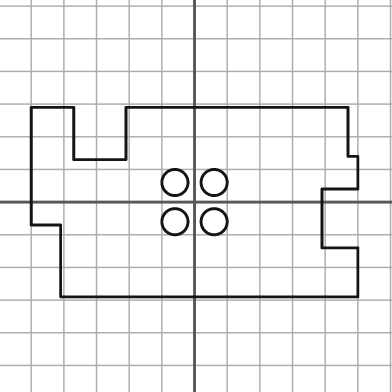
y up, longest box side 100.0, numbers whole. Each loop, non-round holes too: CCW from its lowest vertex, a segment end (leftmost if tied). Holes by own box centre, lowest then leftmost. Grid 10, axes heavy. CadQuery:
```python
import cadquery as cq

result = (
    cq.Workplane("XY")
    .moveTo(-41.0, -29.0)
    .lineTo(50.0, -29.0)
    .lineTo(50.0, -14.0)
    .lineTo(39.0, -14.0)
    .lineTo(39.0, 4.0)
    .lineTo(50.0, 4.0)
    .lineTo(50.0, 14.0)
    .lineTo(47.0, 14.0)
    .lineTo(47.0, 29.0)
    .lineTo(-21.0, 29.0)
    .lineTo(-21.0, 13.0)
    .lineTo(-37.0, 13.0)
    .lineTo(-37.0, 29.0)
    .lineTo(-50.0, 29.0)
    .lineTo(-50.0, -7.0)
    .lineTo(-41.0, -7.0)
    .close()
    .moveTo(-6.0, -6.0)
    .circle(4.0)
    .moveTo(6.0, -6.0)
    .circle(4.0)
    .moveTo(-6.0, 6.0)
    .circle(4.0)
    .moveTo(6.0, 6.0)
    .circle(4.0)
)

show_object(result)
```